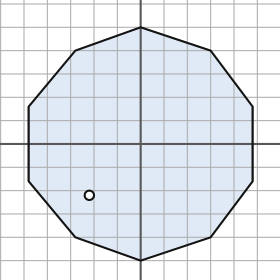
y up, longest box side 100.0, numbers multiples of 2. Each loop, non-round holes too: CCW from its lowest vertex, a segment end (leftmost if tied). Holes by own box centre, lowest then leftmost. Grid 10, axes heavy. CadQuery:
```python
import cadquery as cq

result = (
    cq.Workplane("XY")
    .moveTo(0.0, -50.0)
    .lineTo(30.0, -40.0)
    .lineTo(48.0, -16.0)
    .lineTo(48.0, 16.0)
    .lineTo(30.0, 40.0)
    .lineTo(0.0, 50.0)
    .lineTo(-28.0, 40.0)
    .lineTo(-48.0, 16.0)
    .lineTo(-48.0, -16.0)
    .lineTo(-28.0, -40.0)
    .close()
    .moveTo(-22.0, -22.0)
    .circle(2.0)
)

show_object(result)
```